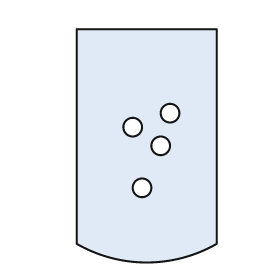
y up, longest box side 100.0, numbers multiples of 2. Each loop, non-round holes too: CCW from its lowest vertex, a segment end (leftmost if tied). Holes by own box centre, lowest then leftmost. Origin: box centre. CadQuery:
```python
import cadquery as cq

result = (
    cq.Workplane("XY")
    .moveTo(-30.0, -42.0)
    .threePointArc((0.0, -50.0), (30.0, -42.0))
    .lineTo(30.0, 50.0)
    .lineTo(-30.0, 50.0)
    .close()
    .moveTo(-2.0, -18.0)
    .circle(4.0)
    .moveTo(6.0, 0.0)
    .circle(4.0)
    .moveTo(-6.0, 8.0)
    .circle(4.0)
    .moveTo(10.0, 14.0)
    .circle(4.0)
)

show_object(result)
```